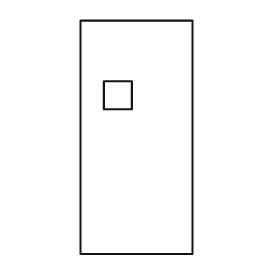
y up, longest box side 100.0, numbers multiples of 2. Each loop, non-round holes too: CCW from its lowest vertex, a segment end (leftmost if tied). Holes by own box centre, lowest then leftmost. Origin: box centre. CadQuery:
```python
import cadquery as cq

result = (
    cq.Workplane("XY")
    .moveTo(-24.0, -50.0)
    .lineTo(24.0, -50.0)
    .lineTo(24.0, 50.0)
    .lineTo(-24.0, 50.0)
    .close()
    .moveTo(-14.0, 12.0)
    .lineTo(-2.0, 12.0)
    .lineTo(-2.0, 24.0)
    .lineTo(-14.0, 24.0)
    .close()
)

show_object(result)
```